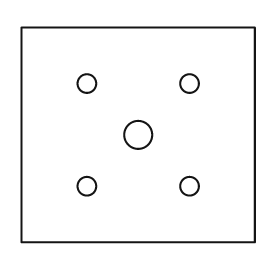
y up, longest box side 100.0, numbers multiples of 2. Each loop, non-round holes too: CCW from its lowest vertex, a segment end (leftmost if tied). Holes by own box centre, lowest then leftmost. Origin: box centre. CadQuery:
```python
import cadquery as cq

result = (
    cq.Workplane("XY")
    .moveTo(-50.0, -46.0)
    .lineTo(50.0, -46.0)
    .lineTo(50.0, 46.0)
    .lineTo(-50.0, 46.0)
    .close()
    .moveTo(-22.0, -22.0)
    .circle(4.0)
    .moveTo(22.0, -22.0)
    .circle(4.0)
    .moveTo(0.0, 0.0)
    .circle(6.0)
    .moveTo(-22.0, 22.0)
    .circle(4.0)
    .moveTo(22.0, 22.0)
    .circle(4.0)
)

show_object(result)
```